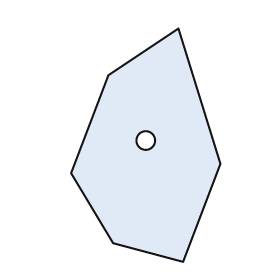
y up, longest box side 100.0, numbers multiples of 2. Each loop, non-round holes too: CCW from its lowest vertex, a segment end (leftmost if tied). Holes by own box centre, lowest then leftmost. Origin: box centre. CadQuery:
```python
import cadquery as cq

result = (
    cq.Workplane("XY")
    .moveTo(16.0, -50.0)
    .lineTo(32.0, -8.0)
    .lineTo(14.0, 50.0)
    .lineTo(-16.0, 30.0)
    .lineTo(-32.0, -12.0)
    .lineTo(-14.0, -42.0)
    .close()
    .moveTo(0.0, 2.0)
    .circle(4.0)
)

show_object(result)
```